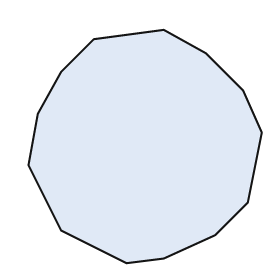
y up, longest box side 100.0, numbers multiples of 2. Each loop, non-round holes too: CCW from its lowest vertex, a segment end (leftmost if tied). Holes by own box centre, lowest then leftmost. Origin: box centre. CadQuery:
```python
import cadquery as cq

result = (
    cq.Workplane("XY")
    .moveTo(-8.0, -50.0)
    .lineTo(8.0, -48.0)
    .lineTo(30.0, -38.0)
    .lineTo(44.0, -24.0)
    .lineTo(50.0, 6.0)
    .lineTo(42.0, 24.0)
    .lineTo(26.0, 40.0)
    .lineTo(8.0, 50.0)
    .lineTo(-22.0, 46.0)
    .lineTo(-36.0, 32.0)
    .lineTo(-46.0, 14.0)
    .lineTo(-50.0, -8.0)
    .lineTo(-36.0, -36.0)
    .close()
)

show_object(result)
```